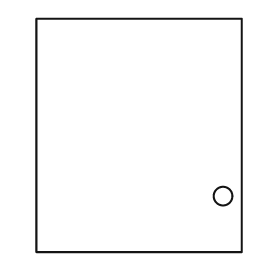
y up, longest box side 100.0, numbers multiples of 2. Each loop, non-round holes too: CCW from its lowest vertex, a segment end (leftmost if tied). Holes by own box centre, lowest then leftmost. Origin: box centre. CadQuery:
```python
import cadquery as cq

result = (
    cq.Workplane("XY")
    .moveTo(-44.0, -50.0)
    .lineTo(44.0, -50.0)
    .lineTo(44.0, 50.0)
    .lineTo(-44.0, 50.0)
    .close()
    .moveTo(36.0, -26.0)
    .circle(4.0)
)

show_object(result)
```